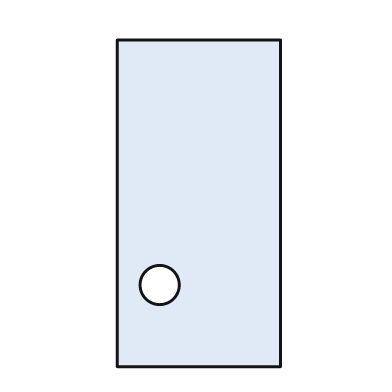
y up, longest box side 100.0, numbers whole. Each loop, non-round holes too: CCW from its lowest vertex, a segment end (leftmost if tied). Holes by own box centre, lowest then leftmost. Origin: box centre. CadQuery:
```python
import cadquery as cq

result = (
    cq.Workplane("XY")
    .moveTo(-25.0, -50.0)
    .lineTo(25.0, -50.0)
    .lineTo(25.0, 50.0)
    .lineTo(-25.0, 50.0)
    .close()
    .moveTo(-12.0, -25.0)
    .circle(6.0)
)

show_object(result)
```